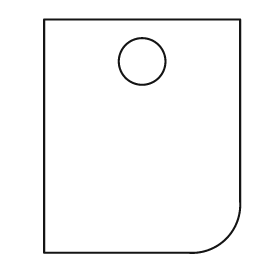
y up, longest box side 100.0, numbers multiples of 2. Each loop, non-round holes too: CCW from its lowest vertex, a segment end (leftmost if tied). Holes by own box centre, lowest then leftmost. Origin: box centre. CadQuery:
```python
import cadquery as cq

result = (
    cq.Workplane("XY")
    .moveTo(-42.0, -50.0)
    .lineTo(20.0, -50.0)
    .threePointArc((36.0, -44.0), (42.0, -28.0))
    .lineTo(42.0, 50.0)
    .lineTo(-42.0, 50.0)
    .close()
    .moveTo(0.0, 32.0)
    .circle(10.0)
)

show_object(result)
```